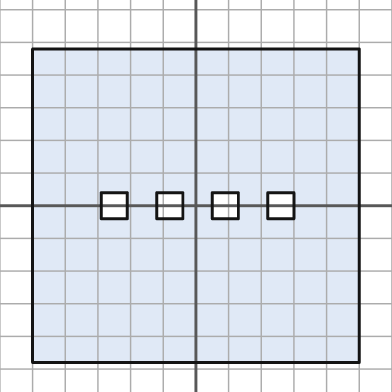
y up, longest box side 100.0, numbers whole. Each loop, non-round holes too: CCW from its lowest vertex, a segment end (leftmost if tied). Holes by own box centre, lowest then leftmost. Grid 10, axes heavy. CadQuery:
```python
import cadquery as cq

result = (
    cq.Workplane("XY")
    .moveTo(-50.0, -48.0)
    .lineTo(50.0, -48.0)
    .lineTo(50.0, 48.0)
    .lineTo(-50.0, 48.0)
    .close()
    .moveTo(-29.0, -4.0)
    .lineTo(-21.0, -4.0)
    .lineTo(-21.0, 4.0)
    .lineTo(-29.0, 4.0)
    .close()
    .moveTo(-12.0, -4.0)
    .lineTo(-4.0, -4.0)
    .lineTo(-4.0, 4.0)
    .lineTo(-12.0, 4.0)
    .close()
    .moveTo(5.0, -4.0)
    .lineTo(13.0, -4.0)
    .lineTo(13.0, 4.0)
    .lineTo(5.0, 4.0)
    .close()
    .moveTo(22.0, -4.0)
    .lineTo(30.0, -4.0)
    .lineTo(30.0, 4.0)
    .lineTo(22.0, 4.0)
    .close()
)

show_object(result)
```